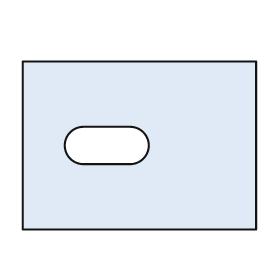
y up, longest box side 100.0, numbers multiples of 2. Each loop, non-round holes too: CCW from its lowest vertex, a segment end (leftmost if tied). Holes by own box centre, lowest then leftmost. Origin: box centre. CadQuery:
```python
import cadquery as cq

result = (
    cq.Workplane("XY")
    .moveTo(-50.0, -36.0)
    .lineTo(50.0, -36.0)
    .lineTo(50.0, 36.0)
    .lineTo(-50.0, 36.0)
    .close()
    .moveTo(-24.0, -8.0)
    .lineTo(-4.0, -8.0)
    .threePointArc((4.0, 0.0), (-4.0, 8.0))
    .lineTo(-24.0, 8.0)
    .threePointArc((-32.0, 0.0), (-24.0, -8.0))
    .close()
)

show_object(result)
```